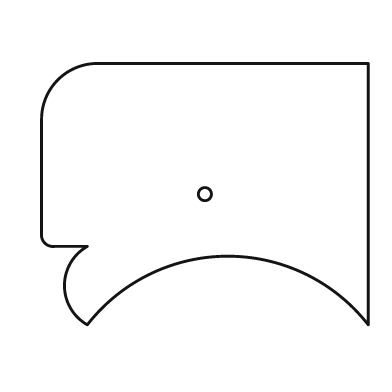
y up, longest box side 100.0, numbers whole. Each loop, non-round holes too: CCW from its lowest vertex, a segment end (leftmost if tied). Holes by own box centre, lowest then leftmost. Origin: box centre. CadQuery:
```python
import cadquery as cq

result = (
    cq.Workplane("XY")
    .moveTo(-36.0, -40.0)
    .threePointArc((7.0, -19.0), (50.0, -40.0))
    .lineTo(50.0, 40.0)
    .lineTo(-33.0, 40.0)
    .threePointArc((-45.0, 35.0), (-50.0, 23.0))
    .lineTo(-50.0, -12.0)
    .threePointArc((-49.0, -15.0), (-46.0, -16.0))
    .lineTo(-36.0, -16.0)
    .threePointArc((-43.0, -28.0), (-36.0, -40.0))
    .close()
    .moveTo(0.0, 0.0)
    .circle(2.0)
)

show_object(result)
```